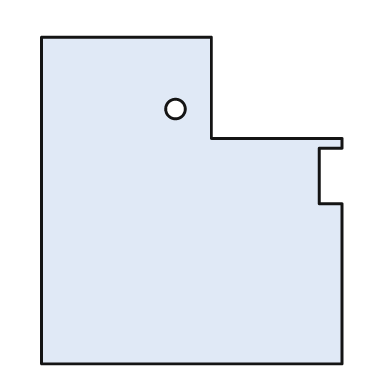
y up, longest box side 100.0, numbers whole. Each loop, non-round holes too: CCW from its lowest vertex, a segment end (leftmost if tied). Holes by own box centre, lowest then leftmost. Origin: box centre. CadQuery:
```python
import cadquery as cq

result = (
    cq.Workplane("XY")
    .moveTo(-46.0, -50.0)
    .lineTo(46.0, -50.0)
    .lineTo(46.0, -1.0)
    .lineTo(39.0, -1.0)
    .lineTo(39.0, 16.0)
    .lineTo(46.0, 16.0)
    .lineTo(46.0, 19.0)
    .lineTo(6.0, 19.0)
    .lineTo(6.0, 50.0)
    .lineTo(-46.0, 50.0)
    .close()
    .moveTo(-5.0, 28.0)
    .circle(3.0)
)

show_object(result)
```